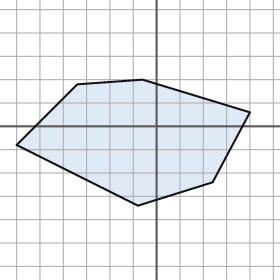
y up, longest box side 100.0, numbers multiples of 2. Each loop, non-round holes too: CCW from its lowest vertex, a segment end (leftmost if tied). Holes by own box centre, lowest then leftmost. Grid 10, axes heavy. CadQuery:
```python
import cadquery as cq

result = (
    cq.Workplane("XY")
    .moveTo(-8.0, -34.0)
    .lineTo(24.0, -24.0)
    .lineTo(40.0, 6.0)
    .lineTo(-6.0, 20.0)
    .lineTo(-34.0, 18.0)
    .lineTo(-60.0, -8.0)
    .close()
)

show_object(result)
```